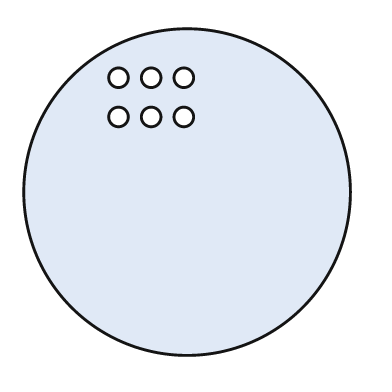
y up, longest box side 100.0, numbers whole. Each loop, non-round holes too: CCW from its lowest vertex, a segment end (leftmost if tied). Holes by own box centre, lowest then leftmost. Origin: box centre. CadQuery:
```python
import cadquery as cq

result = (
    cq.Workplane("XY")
    .moveTo(0.0, 0.0)
    .circle(50.0)
    .moveTo(-21.0, 23.0)
    .circle(3.0)
    .moveTo(-11.0, 23.0)
    .circle(3.0)
    .moveTo(-1.0, 23.0)
    .circle(3.0)
    .moveTo(-21.0, 35.0)
    .circle(3.0)
    .moveTo(-11.0, 35.0)
    .circle(3.0)
    .moveTo(-1.0, 35.0)
    .circle(3.0)
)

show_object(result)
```